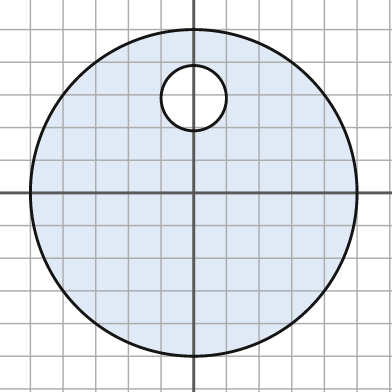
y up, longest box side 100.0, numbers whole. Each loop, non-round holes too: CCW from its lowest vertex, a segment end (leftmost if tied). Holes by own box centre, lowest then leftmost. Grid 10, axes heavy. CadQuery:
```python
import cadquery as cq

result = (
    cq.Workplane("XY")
    .moveTo(0.0, 0.0)
    .circle(50.0)
    .moveTo(0.0, 29.0)
    .circle(10.0)
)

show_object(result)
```